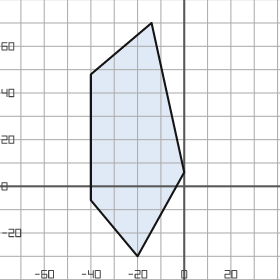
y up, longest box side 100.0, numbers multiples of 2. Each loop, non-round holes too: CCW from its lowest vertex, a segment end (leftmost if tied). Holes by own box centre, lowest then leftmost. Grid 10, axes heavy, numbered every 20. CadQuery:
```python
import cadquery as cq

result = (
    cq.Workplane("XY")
    .moveTo(-20.0, -30.0)
    .lineTo(0.0, 6.0)
    .lineTo(-14.0, 70.0)
    .lineTo(-40.0, 48.0)
    .lineTo(-40.0, -6.0)
    .close()
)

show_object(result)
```